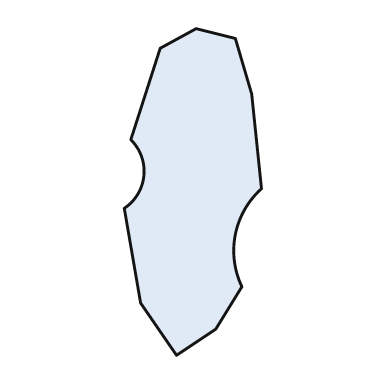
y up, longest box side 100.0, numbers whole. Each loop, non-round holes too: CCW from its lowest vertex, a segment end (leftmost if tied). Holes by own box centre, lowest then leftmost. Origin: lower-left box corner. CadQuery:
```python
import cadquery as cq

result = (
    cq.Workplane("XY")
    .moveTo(16.0, 0.0)
    .lineTo(28.0, 8.0)
    .lineTo(36.0, 21.0)
    .threePointArc((34.0, 37.0), (42.0, 51.0))
    .lineTo(39.0, 80.0)
    .lineTo(34.0, 97.0)
    .lineTo(22.0, 100.0)
    .lineTo(11.0, 94.0)
    .lineTo(2.0, 66.0)
    .threePointArc((6.0, 55.0), (0.0, 45.0))
    .lineTo(5.0, 16.0)
    .close()
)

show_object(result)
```